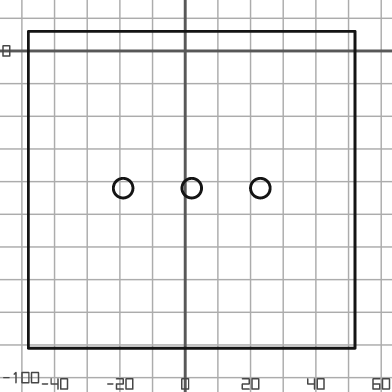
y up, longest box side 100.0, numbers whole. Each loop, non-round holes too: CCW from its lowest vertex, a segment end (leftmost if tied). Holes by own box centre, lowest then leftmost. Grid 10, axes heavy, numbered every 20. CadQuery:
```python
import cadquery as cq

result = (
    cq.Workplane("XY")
    .moveTo(-48.0, -91.0)
    .lineTo(52.0, -91.0)
    .lineTo(52.0, 6.0)
    .lineTo(-48.0, 6.0)
    .close()
    .moveTo(-19.0, -42.0)
    .circle(3.0)
    .moveTo(2.0, -42.0)
    .circle(3.0)
    .moveTo(23.0, -42.0)
    .circle(3.0)
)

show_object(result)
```